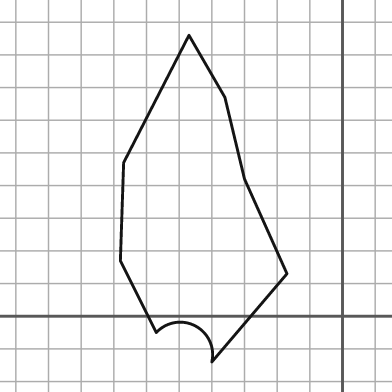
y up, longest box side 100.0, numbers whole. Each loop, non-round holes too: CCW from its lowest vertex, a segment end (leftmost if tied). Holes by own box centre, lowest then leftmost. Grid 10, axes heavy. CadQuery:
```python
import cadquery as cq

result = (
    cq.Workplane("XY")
    .moveTo(-40.0, -14.0)
    .lineTo(-17.0, 13.0)
    .lineTo(-30.0, 42.0)
    .lineTo(-36.0, 67.0)
    .lineTo(-47.0, 86.0)
    .lineTo(-67.0, 47.0)
    .lineTo(-68.0, 17.0)
    .lineTo(-57.0, -5.0)
    .threePointArc((-45.0, -3.0), (-40.0, -14.0))
    .close()
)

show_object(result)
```